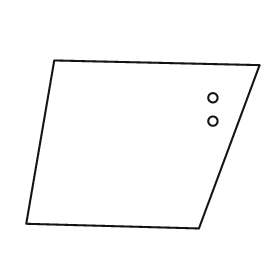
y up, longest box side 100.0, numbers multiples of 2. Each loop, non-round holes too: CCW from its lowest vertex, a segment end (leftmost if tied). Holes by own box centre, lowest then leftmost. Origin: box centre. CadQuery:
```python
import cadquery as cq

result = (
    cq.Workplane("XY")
    .moveTo(24.0, -36.0)
    .lineTo(50.0, 34.0)
    .lineTo(-38.0, 36.0)
    .lineTo(-50.0, -34.0)
    .close()
    .moveTo(30.0, 10.0)
    .circle(2.0)
    .moveTo(30.0, 20.0)
    .circle(2.0)
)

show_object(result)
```